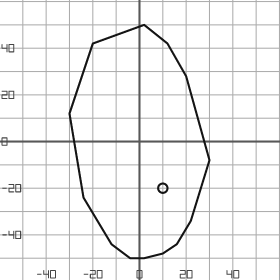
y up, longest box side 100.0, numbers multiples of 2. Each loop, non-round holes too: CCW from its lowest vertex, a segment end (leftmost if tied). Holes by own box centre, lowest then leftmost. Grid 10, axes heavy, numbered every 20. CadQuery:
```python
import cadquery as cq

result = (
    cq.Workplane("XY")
    .moveTo(-4.0, -50.0)
    .lineTo(2.0, -50.0)
    .lineTo(10.0, -48.0)
    .lineTo(16.0, -44.0)
    .lineTo(22.0, -34.0)
    .lineTo(30.0, -8.0)
    .lineTo(20.0, 28.0)
    .lineTo(12.0, 42.0)
    .lineTo(2.0, 50.0)
    .lineTo(-20.0, 42.0)
    .lineTo(-30.0, 12.0)
    .lineTo(-24.0, -24.0)
    .lineTo(-12.0, -44.0)
    .close()
    .moveTo(10.0, -20.0)
    .circle(2.0)
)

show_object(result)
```